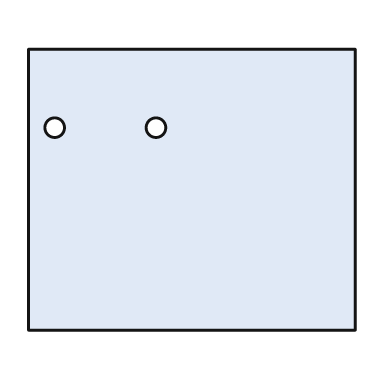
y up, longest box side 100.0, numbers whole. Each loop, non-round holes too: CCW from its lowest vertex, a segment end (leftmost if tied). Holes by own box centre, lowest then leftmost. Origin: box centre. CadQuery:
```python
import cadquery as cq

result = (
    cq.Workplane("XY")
    .moveTo(-50.0, -43.0)
    .lineTo(50.0, -43.0)
    .lineTo(50.0, 43.0)
    .lineTo(-50.0, 43.0)
    .close()
    .moveTo(-42.0, 19.0)
    .circle(3.0)
    .moveTo(-11.0, 19.0)
    .circle(3.0)
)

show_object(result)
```